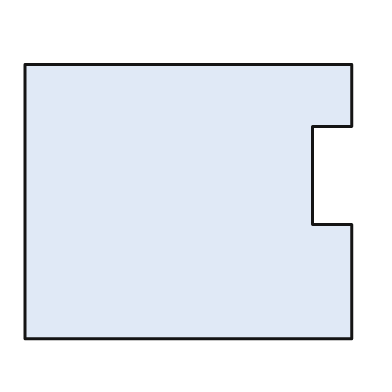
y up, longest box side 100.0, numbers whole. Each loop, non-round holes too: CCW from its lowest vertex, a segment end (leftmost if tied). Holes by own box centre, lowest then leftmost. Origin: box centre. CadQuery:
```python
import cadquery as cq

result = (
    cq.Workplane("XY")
    .moveTo(-50.0, -42.0)
    .lineTo(50.0, -42.0)
    .lineTo(50.0, -7.0)
    .lineTo(38.0, -7.0)
    .lineTo(38.0, 23.0)
    .lineTo(50.0, 23.0)
    .lineTo(50.0, 42.0)
    .lineTo(-50.0, 42.0)
    .close()
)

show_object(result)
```